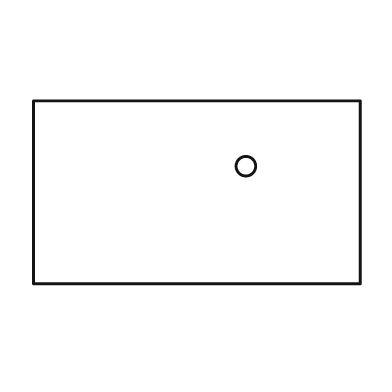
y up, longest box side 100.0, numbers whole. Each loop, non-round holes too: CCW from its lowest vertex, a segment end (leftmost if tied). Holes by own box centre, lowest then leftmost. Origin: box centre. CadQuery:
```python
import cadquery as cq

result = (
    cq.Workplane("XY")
    .moveTo(-50.0, -28.0)
    .lineTo(50.0, -28.0)
    .lineTo(50.0, 28.0)
    .lineTo(-50.0, 28.0)
    .close()
    .moveTo(15.0, 8.0)
    .circle(3.0)
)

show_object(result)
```